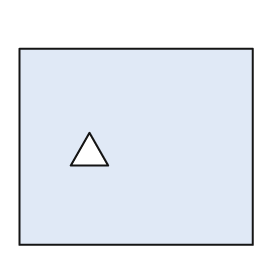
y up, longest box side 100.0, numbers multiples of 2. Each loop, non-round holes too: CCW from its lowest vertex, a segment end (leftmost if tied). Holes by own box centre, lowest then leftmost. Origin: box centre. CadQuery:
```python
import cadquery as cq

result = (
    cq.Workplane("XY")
    .moveTo(-50.0, -42.0)
    .lineTo(50.0, -42.0)
    .lineTo(50.0, 42.0)
    .lineTo(-50.0, 42.0)
    .close()
    .moveTo(-28.0, -8.0)
    .lineTo(-12.0, -8.0)
    .lineTo(-20.0, 6.0)
    .close()
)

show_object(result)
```